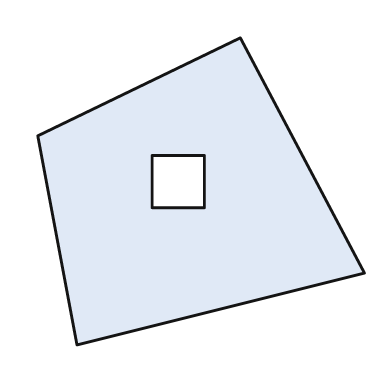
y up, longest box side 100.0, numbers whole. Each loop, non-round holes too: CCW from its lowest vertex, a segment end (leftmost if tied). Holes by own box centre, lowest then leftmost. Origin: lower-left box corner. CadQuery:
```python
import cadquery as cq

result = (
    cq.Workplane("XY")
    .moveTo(12.0, 0.0)
    .lineTo(100.0, 22.0)
    .lineTo(62.0, 94.0)
    .lineTo(0.0, 64.0)
    .close()
    .moveTo(35.0, 42.0)
    .lineTo(51.0, 42.0)
    .lineTo(51.0, 58.0)
    .lineTo(35.0, 58.0)
    .close()
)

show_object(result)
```